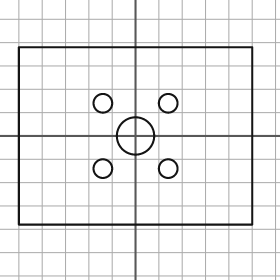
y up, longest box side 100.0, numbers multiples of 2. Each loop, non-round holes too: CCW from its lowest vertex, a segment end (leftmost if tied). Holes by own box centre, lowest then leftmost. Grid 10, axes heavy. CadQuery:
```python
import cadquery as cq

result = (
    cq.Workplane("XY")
    .moveTo(-50.0, -38.0)
    .lineTo(50.0, -38.0)
    .lineTo(50.0, 38.0)
    .lineTo(-50.0, 38.0)
    .close()
    .moveTo(-14.0, -14.0)
    .circle(4.0)
    .moveTo(14.0, -14.0)
    .circle(4.0)
    .moveTo(0.0, 0.0)
    .circle(8.0)
    .moveTo(-14.0, 14.0)
    .circle(4.0)
    .moveTo(14.0, 14.0)
    .circle(4.0)
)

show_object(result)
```